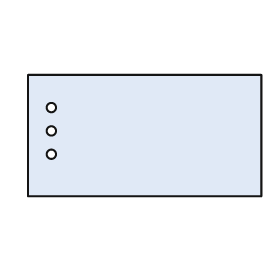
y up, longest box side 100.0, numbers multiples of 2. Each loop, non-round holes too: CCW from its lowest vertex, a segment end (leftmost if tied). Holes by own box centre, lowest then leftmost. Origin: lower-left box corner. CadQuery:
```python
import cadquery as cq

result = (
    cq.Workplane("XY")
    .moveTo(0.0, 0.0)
    .lineTo(100.0, 0.0)
    .lineTo(100.0, 52.0)
    .lineTo(0.0, 52.0)
    .close()
    .moveTo(10.0, 18.0)
    .circle(2.0)
    .moveTo(10.0, 28.0)
    .circle(2.0)
    .moveTo(10.0, 38.0)
    .circle(2.0)
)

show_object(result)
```